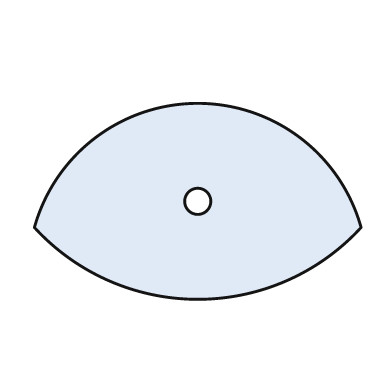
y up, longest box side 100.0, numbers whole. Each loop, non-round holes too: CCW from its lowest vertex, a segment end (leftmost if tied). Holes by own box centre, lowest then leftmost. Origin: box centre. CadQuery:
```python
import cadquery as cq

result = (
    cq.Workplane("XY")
    .moveTo(-50.0, -8.0)
    .threePointArc((0.0, -30.0), (50.0, -8.0))
    .threePointArc((0.0, 30.0), (-50.0, -8.0))
    .close()
    .moveTo(0.0, 0.0)
    .circle(4.0)
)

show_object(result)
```